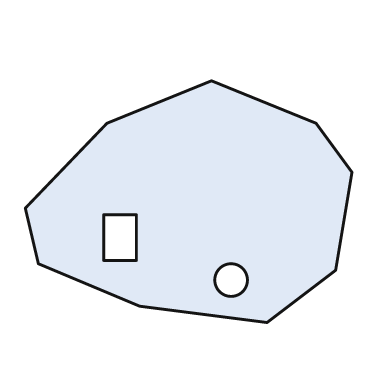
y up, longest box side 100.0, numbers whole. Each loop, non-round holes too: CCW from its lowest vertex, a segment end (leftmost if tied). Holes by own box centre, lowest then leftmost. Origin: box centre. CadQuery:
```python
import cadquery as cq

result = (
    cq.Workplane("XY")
    .moveTo(24.0, -37.0)
    .lineTo(45.0, -21.0)
    .lineTo(50.0, 9.0)
    .lineTo(39.0, 24.0)
    .lineTo(7.0, 37.0)
    .lineTo(-25.0, 24.0)
    .lineTo(-50.0, -2.0)
    .lineTo(-46.0, -19.0)
    .lineTo(-15.0, -32.0)
    .close()
    .moveTo(13.0, -24.0)
    .circle(5.0)
    .moveTo(-26.0, -18.0)
    .lineTo(-16.0, -18.0)
    .lineTo(-16.0, -4.0)
    .lineTo(-26.0, -4.0)
    .close()
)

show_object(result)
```